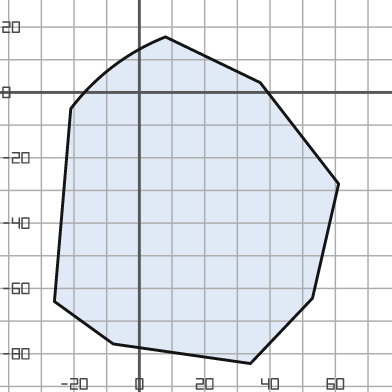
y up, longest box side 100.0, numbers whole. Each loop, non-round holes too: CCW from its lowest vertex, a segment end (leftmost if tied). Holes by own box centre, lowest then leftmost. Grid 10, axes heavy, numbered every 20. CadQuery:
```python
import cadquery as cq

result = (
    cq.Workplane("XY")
    .moveTo(34.0, -83.0)
    .lineTo(53.0, -63.0)
    .lineTo(61.0, -28.0)
    .lineTo(37.0, 3.0)
    .lineTo(8.0, 17.0)
    .threePointArc((-8.0, 8.0), (-21.0, -5.0))
    .lineTo(-26.0, -64.0)
    .lineTo(-8.0, -77.0)
    .close()
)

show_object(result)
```